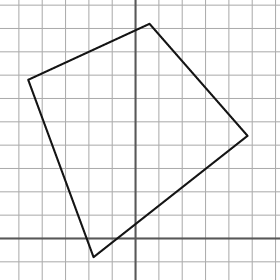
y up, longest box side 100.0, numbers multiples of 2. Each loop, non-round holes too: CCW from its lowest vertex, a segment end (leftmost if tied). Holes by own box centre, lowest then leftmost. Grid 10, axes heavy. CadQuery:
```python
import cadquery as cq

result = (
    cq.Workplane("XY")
    .moveTo(-18.0, -8.0)
    .lineTo(48.0, 44.0)
    .lineTo(6.0, 92.0)
    .lineTo(-46.0, 68.0)
    .close()
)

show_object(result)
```